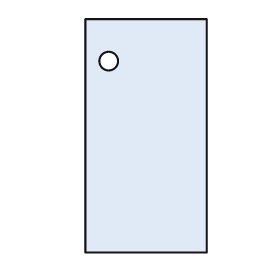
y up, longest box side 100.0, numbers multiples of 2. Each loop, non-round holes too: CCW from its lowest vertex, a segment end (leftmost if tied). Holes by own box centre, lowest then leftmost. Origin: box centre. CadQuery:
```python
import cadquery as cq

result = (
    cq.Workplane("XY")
    .moveTo(-26.0, -50.0)
    .lineTo(26.0, -50.0)
    .lineTo(26.0, 50.0)
    .lineTo(-26.0, 50.0)
    .close()
    .moveTo(-16.0, 32.0)
    .circle(4.0)
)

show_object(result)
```